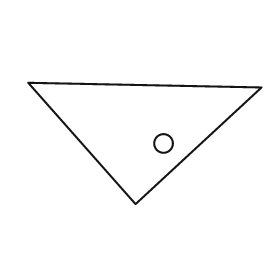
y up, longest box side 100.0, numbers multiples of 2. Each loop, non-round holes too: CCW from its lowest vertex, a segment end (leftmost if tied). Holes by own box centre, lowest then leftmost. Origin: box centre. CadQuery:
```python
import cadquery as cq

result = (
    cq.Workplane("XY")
    .moveTo(-4.0, -26.0)
    .lineTo(50.0, 24.0)
    .lineTo(-50.0, 26.0)
    .close()
    .moveTo(8.0, 0.0)
    .circle(4.0)
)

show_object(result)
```